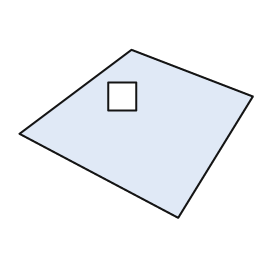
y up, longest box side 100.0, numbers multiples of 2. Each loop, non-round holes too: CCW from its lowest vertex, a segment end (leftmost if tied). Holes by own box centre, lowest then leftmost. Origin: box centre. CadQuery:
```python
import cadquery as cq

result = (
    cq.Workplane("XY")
    .moveTo(18.0, -36.0)
    .lineTo(50.0, 16.0)
    .lineTo(-2.0, 36.0)
    .lineTo(-50.0, 0.0)
    .close()
    .moveTo(-12.0, 10.0)
    .lineTo(0.0, 10.0)
    .lineTo(0.0, 22.0)
    .lineTo(-12.0, 22.0)
    .close()
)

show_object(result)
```